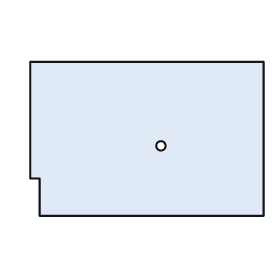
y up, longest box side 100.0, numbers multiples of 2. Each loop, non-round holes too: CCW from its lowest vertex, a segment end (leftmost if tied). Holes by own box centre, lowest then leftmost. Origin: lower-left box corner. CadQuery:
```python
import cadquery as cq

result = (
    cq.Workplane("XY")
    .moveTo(4.0, 0.0)
    .lineTo(100.0, 0.0)
    .lineTo(100.0, 66.0)
    .lineTo(0.0, 66.0)
    .lineTo(0.0, 16.0)
    .lineTo(4.0, 16.0)
    .close()
    .moveTo(56.0, 30.0)
    .circle(2.0)
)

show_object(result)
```